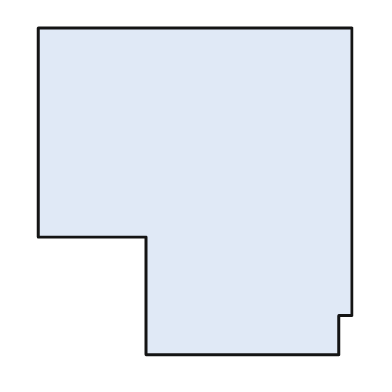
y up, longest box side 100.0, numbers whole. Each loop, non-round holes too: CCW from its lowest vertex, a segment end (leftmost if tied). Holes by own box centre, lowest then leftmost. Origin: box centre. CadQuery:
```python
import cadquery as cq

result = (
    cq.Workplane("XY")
    .moveTo(-15.0, -50.0)
    .lineTo(44.0, -50.0)
    .lineTo(44.0, -38.0)
    .lineTo(48.0, -38.0)
    .lineTo(48.0, 50.0)
    .lineTo(-48.0, 50.0)
    .lineTo(-48.0, -14.0)
    .lineTo(-15.0, -14.0)
    .close()
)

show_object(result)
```